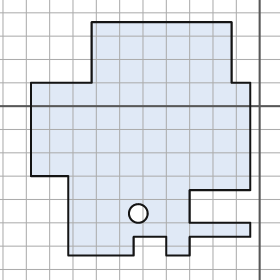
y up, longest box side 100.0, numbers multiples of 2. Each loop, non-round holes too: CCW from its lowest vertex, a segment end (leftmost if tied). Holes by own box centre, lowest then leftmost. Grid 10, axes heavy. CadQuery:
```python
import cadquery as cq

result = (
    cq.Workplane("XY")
    .moveTo(-82.0, -64.0)
    .lineTo(-54.0, -64.0)
    .lineTo(-54.0, -56.0)
    .lineTo(-40.0, -56.0)
    .lineTo(-40.0, -64.0)
    .lineTo(-30.0, -64.0)
    .lineTo(-30.0, -56.0)
    .lineTo(-4.0, -56.0)
    .lineTo(-4.0, -50.0)
    .lineTo(-30.0, -50.0)
    .lineTo(-30.0, -36.0)
    .lineTo(-4.0, -36.0)
    .lineTo(-4.0, 10.0)
    .lineTo(-12.0, 10.0)
    .lineTo(-12.0, 36.0)
    .lineTo(-72.0, 36.0)
    .lineTo(-72.0, 10.0)
    .lineTo(-98.0, 10.0)
    .lineTo(-98.0, -30.0)
    .lineTo(-82.0, -30.0)
    .close()
    .moveTo(-52.0, -46.0)
    .circle(4.0)
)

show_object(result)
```